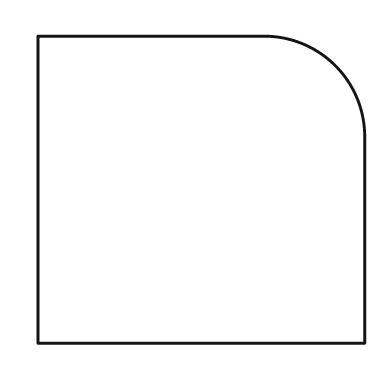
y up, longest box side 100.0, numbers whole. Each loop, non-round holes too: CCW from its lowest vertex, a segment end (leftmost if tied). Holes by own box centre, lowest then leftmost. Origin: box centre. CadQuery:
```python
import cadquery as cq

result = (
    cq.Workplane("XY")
    .moveTo(-50.0, -47.0)
    .lineTo(50.0, -47.0)
    .lineTo(50.0, 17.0)
    .threePointArc((41.0, 38.0), (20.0, 47.0))
    .lineTo(-50.0, 47.0)
    .close()
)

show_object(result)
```